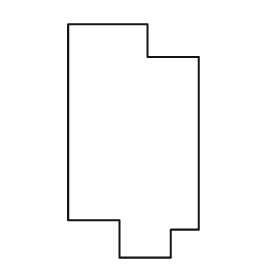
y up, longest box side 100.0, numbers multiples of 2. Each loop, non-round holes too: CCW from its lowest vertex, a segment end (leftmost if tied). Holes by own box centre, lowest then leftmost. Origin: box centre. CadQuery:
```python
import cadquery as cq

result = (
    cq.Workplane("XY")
    .moveTo(-6.0, -50.0)
    .lineTo(16.0, -50.0)
    .lineTo(16.0, -38.0)
    .lineTo(28.0, -38.0)
    .lineTo(28.0, 36.0)
    .lineTo(6.0, 36.0)
    .lineTo(6.0, 50.0)
    .lineTo(-28.0, 50.0)
    .lineTo(-28.0, -34.0)
    .lineTo(-6.0, -34.0)
    .close()
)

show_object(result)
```